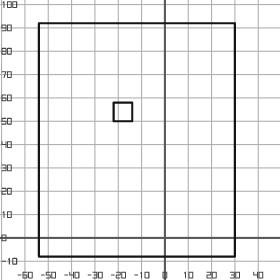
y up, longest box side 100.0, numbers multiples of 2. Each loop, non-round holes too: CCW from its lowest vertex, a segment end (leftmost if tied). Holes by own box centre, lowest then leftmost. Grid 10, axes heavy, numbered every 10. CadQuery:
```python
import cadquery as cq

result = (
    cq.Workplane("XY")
    .moveTo(-54.0, -8.0)
    .lineTo(30.0, -8.0)
    .lineTo(30.0, 92.0)
    .lineTo(-54.0, 92.0)
    .close()
    .moveTo(-22.0, 50.0)
    .lineTo(-14.0, 50.0)
    .lineTo(-14.0, 58.0)
    .lineTo(-22.0, 58.0)
    .close()
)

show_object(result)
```